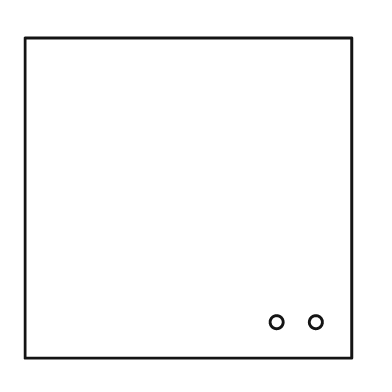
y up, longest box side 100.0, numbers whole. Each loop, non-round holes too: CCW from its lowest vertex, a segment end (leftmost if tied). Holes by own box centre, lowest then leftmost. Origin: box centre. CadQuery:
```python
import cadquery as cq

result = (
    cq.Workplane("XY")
    .moveTo(-50.0, -49.0)
    .lineTo(50.0, -49.0)
    .lineTo(50.0, 49.0)
    .lineTo(-50.0, 49.0)
    .close()
    .moveTo(27.0, -38.0)
    .circle(2.0)
    .moveTo(39.0, -38.0)
    .circle(2.0)
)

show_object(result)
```